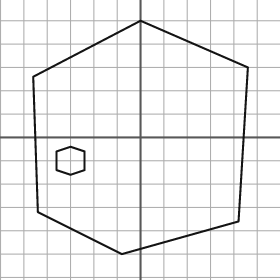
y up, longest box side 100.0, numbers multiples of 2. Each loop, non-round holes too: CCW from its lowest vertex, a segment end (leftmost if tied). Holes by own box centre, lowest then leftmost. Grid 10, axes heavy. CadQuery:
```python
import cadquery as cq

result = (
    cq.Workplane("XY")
    .moveTo(-8.0, -50.0)
    .lineTo(42.0, -36.0)
    .lineTo(46.0, 30.0)
    .lineTo(0.0, 50.0)
    .lineTo(-46.0, 26.0)
    .lineTo(-44.0, -32.0)
    .close()
    .moveTo(-30.0, -16.0)
    .lineTo(-24.0, -14.0)
    .lineTo(-24.0, -6.0)
    .lineTo(-30.0, -4.0)
    .lineTo(-36.0, -6.0)
    .lineTo(-36.0, -14.0)
    .close()
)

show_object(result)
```